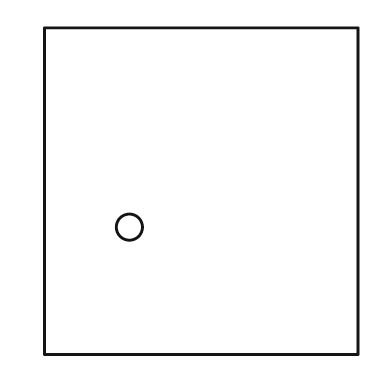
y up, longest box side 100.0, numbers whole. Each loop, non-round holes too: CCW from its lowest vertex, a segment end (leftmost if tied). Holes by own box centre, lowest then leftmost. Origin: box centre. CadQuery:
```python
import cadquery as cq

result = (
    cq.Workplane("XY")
    .moveTo(-48.0, -50.0)
    .lineTo(48.0, -50.0)
    .lineTo(48.0, 50.0)
    .lineTo(-48.0, 50.0)
    .close()
    .moveTo(-22.0, -11.0)
    .circle(4.0)
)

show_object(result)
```